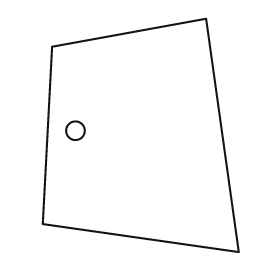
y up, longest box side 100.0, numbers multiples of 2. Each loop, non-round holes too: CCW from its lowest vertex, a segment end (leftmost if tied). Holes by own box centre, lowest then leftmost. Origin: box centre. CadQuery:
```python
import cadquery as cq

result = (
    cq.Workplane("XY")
    .moveTo(42.0, -50.0)
    .lineTo(28.0, 50.0)
    .lineTo(-38.0, 38.0)
    .lineTo(-42.0, -38.0)
    .close()
    .moveTo(-28.0, 2.0)
    .circle(4.0)
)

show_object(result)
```